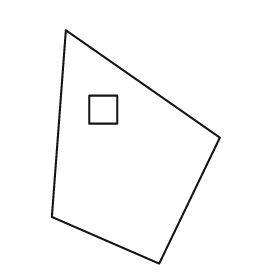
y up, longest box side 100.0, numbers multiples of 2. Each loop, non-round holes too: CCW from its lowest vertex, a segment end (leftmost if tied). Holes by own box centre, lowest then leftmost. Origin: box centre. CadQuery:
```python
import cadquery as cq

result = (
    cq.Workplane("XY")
    .moveTo(10.0, -50.0)
    .lineTo(36.0, 4.0)
    .lineTo(-30.0, 50.0)
    .lineTo(-36.0, -30.0)
    .close()
    .moveTo(-20.0, 10.0)
    .lineTo(-8.0, 10.0)
    .lineTo(-8.0, 22.0)
    .lineTo(-20.0, 22.0)
    .close()
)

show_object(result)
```